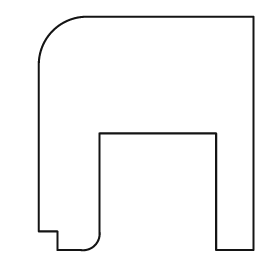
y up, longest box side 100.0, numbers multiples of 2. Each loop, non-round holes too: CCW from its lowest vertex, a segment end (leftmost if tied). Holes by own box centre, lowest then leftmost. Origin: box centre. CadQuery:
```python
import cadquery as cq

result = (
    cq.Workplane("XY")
    .moveTo(-38.0, -50.0)
    .lineTo(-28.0, -50.0)
    .threePointArc((-22.0, -48.0), (-20.0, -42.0))
    .lineTo(-20.0, 0.0)
    .lineTo(30.0, 0.0)
    .lineTo(30.0, -50.0)
    .lineTo(46.0, -50.0)
    .lineTo(46.0, 50.0)
    .lineTo(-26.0, 50.0)
    .threePointArc((-40.0, 44.0), (-46.0, 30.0))
    .lineTo(-46.0, -42.0)
    .lineTo(-38.0, -42.0)
    .close()
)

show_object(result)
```